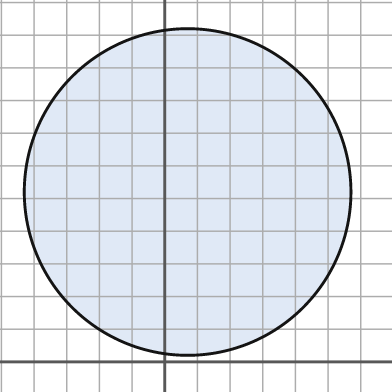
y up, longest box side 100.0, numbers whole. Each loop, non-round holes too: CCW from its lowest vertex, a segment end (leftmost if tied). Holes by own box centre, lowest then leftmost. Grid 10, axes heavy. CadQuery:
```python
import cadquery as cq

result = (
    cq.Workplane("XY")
    .moveTo(7.0, 52.0)
    .circle(50.0)
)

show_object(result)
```